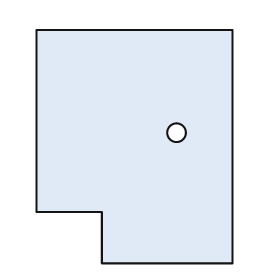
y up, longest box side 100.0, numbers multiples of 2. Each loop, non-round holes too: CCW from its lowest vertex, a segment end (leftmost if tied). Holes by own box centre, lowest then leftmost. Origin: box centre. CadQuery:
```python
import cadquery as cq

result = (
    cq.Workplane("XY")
    .moveTo(-14.0, -50.0)
    .lineTo(42.0, -50.0)
    .lineTo(42.0, 50.0)
    .lineTo(-42.0, 50.0)
    .lineTo(-42.0, -28.0)
    .lineTo(-14.0, -28.0)
    .close()
    .moveTo(18.0, 6.0)
    .circle(4.0)
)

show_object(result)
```